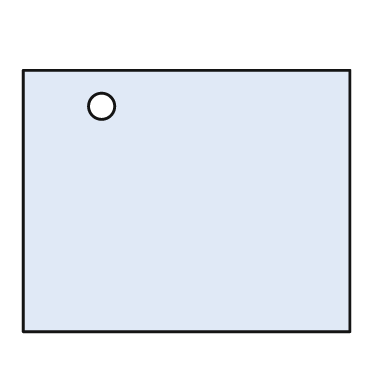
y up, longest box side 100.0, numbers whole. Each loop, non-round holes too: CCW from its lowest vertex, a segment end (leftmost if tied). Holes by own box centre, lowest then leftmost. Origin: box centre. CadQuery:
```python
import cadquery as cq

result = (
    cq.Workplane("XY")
    .moveTo(-50.0, -40.0)
    .lineTo(50.0, -40.0)
    .lineTo(50.0, 40.0)
    .lineTo(-50.0, 40.0)
    .close()
    .moveTo(-26.0, 29.0)
    .circle(4.0)
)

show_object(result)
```